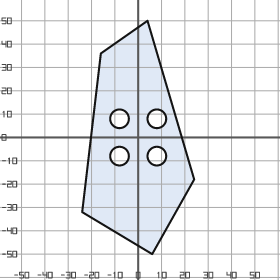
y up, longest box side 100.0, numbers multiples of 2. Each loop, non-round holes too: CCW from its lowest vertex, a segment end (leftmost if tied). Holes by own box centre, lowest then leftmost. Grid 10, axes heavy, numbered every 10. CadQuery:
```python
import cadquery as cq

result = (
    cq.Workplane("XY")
    .moveTo(6.0, -50.0)
    .lineTo(24.0, -18.0)
    .lineTo(4.0, 50.0)
    .lineTo(-16.0, 36.0)
    .lineTo(-24.0, -32.0)
    .close()
    .moveTo(-8.0, -8.0)
    .circle(4.0)
    .moveTo(8.0, -8.0)
    .circle(4.0)
    .moveTo(-8.0, 8.0)
    .circle(4.0)
    .moveTo(8.0, 8.0)
    .circle(4.0)
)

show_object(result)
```